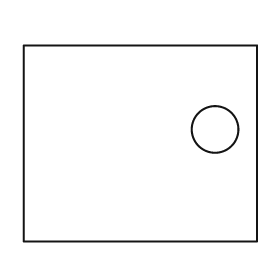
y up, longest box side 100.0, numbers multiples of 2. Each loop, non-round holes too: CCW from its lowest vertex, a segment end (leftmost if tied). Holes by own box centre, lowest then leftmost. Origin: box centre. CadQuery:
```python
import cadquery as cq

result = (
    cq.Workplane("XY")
    .moveTo(-50.0, -42.0)
    .lineTo(50.0, -42.0)
    .lineTo(50.0, 42.0)
    .lineTo(-50.0, 42.0)
    .close()
    .moveTo(32.0, 6.0)
    .circle(10.0)
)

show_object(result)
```